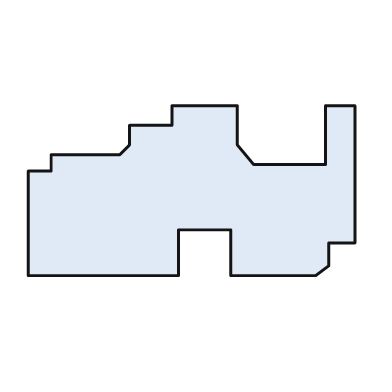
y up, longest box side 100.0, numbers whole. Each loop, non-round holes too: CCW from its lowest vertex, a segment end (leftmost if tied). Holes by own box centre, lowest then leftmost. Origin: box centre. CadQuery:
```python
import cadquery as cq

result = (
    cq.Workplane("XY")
    .moveTo(-50.0, -26.0)
    .lineTo(-4.0, -26.0)
    .lineTo(-4.0, -12.0)
    .lineTo(12.0, -12.0)
    .lineTo(12.0, -26.0)
    .lineTo(38.0, -26.0)
    .lineTo(42.0, -23.0)
    .lineTo(42.0, -16.0)
    .lineTo(50.0, -16.0)
    .lineTo(50.0, 26.0)
    .lineTo(41.0, 26.0)
    .lineTo(41.0, 8.0)
    .lineTo(19.0, 8.0)
    .lineTo(14.0, 14.0)
    .lineTo(14.0, 26.0)
    .lineTo(-6.0, 26.0)
    .lineTo(-6.0, 20.0)
    .lineTo(-19.0, 20.0)
    .lineTo(-19.0, 14.0)
    .lineTo(-22.0, 11.0)
    .lineTo(-43.0, 11.0)
    .lineTo(-43.0, 6.0)
    .lineTo(-50.0, 6.0)
    .close()
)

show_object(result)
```